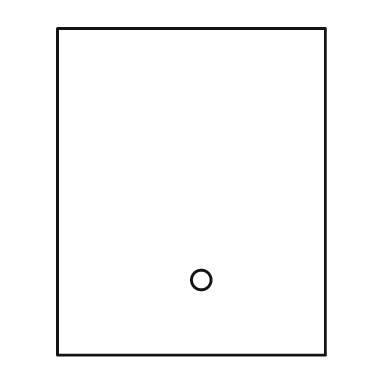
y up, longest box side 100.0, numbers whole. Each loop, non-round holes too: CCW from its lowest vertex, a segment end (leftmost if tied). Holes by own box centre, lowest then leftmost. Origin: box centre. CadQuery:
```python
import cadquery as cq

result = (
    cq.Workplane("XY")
    .moveTo(-41.0, -50.0)
    .lineTo(41.0, -50.0)
    .lineTo(41.0, 50.0)
    .lineTo(-41.0, 50.0)
    .close()
    .moveTo(3.0, -27.0)
    .circle(3.0)
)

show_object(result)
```